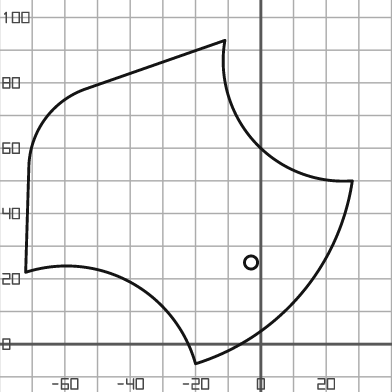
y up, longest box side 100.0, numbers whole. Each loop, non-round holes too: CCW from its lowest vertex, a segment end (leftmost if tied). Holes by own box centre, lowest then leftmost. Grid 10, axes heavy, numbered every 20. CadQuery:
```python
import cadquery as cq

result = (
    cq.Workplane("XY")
    .moveTo(-20.0, -6.0)
    .threePointArc((12.0, 15.0), (28.0, 50.0))
    .threePointArc((-2.0, 62.0), (-11.0, 93.0))
    .lineTo(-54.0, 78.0)
    .threePointArc((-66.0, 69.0), (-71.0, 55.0))
    .lineTo(-72.0, 22.0)
    .threePointArc((-40.0, 19.0), (-20.0, -6.0))
    .close()
    .moveTo(-3.0, 25.0)
    .circle(2.0)
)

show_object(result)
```